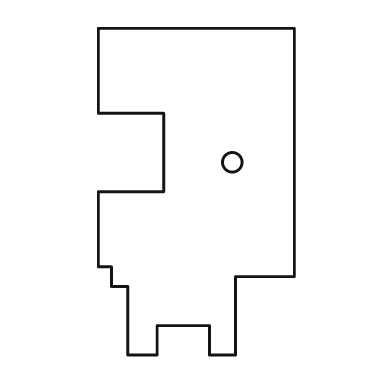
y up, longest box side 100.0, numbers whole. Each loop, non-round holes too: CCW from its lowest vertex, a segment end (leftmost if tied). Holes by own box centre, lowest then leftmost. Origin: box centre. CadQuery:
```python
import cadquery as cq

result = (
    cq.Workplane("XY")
    .moveTo(-21.0, -50.0)
    .lineTo(-12.0, -50.0)
    .lineTo(-12.0, -41.0)
    .lineTo(4.0, -41.0)
    .lineTo(4.0, -50.0)
    .lineTo(12.0, -50.0)
    .lineTo(12.0, -26.0)
    .lineTo(30.0, -26.0)
    .lineTo(30.0, 50.0)
    .lineTo(-30.0, 50.0)
    .lineTo(-30.0, 24.0)
    .lineTo(-10.0, 24.0)
    .lineTo(-10.0, 0.0)
    .lineTo(-30.0, 0.0)
    .lineTo(-30.0, -23.0)
    .lineTo(-26.0, -23.0)
    .lineTo(-26.0, -29.0)
    .lineTo(-21.0, -29.0)
    .close()
    .moveTo(11.0, 9.0)
    .circle(3.0)
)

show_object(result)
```